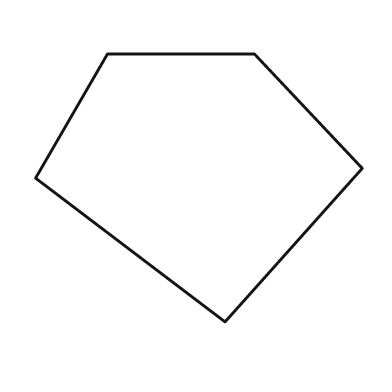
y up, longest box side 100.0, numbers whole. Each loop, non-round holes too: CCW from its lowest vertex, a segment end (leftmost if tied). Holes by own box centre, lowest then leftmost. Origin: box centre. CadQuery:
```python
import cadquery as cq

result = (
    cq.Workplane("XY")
    .moveTo(8.0, -41.0)
    .lineTo(50.0, 6.0)
    .lineTo(17.0, 41.0)
    .lineTo(-28.0, 41.0)
    .lineTo(-50.0, 3.0)
    .close()
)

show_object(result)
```